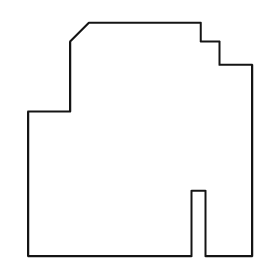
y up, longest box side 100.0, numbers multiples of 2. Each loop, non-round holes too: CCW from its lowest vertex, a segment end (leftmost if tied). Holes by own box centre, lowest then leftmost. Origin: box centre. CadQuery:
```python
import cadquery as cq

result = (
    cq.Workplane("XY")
    .moveTo(-48.0, -50.0)
    .lineTo(22.0, -50.0)
    .lineTo(22.0, -22.0)
    .lineTo(28.0, -22.0)
    .lineTo(28.0, -50.0)
    .lineTo(48.0, -50.0)
    .lineTo(48.0, 32.0)
    .lineTo(34.0, 32.0)
    .lineTo(34.0, 42.0)
    .lineTo(26.0, 42.0)
    .lineTo(26.0, 50.0)
    .lineTo(-22.0, 50.0)
    .lineTo(-30.0, 42.0)
    .lineTo(-30.0, 12.0)
    .lineTo(-48.0, 12.0)
    .close()
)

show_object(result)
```